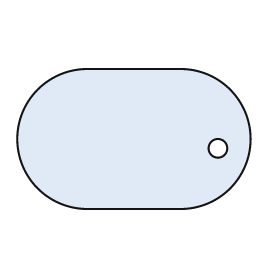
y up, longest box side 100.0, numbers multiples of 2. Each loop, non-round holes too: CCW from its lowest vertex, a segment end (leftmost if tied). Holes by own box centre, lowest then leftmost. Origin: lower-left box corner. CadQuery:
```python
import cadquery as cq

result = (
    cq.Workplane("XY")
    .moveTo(30.0, 0.0)
    .lineTo(70.0, 0.0)
    .threePointArc((100.0, 30.0), (70.0, 60.0))
    .lineTo(30.0, 60.0)
    .threePointArc((0.0, 30.0), (30.0, 0.0))
    .close()
    .moveTo(86.0, 26.0)
    .circle(4.0)
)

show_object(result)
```